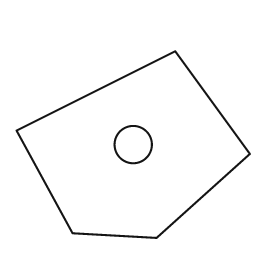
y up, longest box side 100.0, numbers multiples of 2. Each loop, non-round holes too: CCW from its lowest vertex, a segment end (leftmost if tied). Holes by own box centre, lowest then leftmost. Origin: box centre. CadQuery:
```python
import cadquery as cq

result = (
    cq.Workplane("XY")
    .moveTo(10.0, -40.0)
    .lineTo(50.0, -4.0)
    .lineTo(18.0, 40.0)
    .lineTo(-50.0, 6.0)
    .lineTo(-26.0, -38.0)
    .close()
    .moveTo(0.0, 0.0)
    .circle(8.0)
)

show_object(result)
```